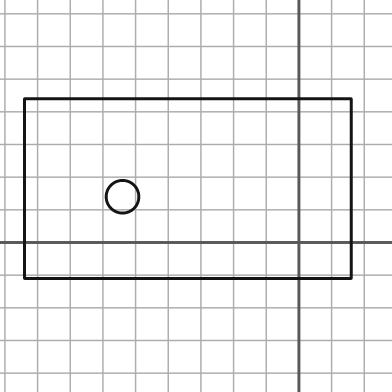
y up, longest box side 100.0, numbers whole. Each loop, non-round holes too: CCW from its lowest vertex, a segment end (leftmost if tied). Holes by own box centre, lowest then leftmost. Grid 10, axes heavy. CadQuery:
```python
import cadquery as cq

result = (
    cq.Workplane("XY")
    .moveTo(-84.0, -11.0)
    .lineTo(16.0, -11.0)
    .lineTo(16.0, 44.0)
    .lineTo(-84.0, 44.0)
    .close()
    .moveTo(-54.0, 14.0)
    .circle(5.0)
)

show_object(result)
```